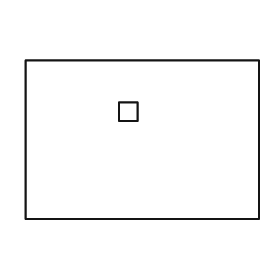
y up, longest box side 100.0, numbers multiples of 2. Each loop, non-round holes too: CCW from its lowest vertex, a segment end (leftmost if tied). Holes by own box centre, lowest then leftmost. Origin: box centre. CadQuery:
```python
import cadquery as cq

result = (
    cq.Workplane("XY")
    .moveTo(-50.0, -34.0)
    .lineTo(50.0, -34.0)
    .lineTo(50.0, 34.0)
    .lineTo(-50.0, 34.0)
    .close()
    .moveTo(-10.0, 8.0)
    .lineTo(-2.0, 8.0)
    .lineTo(-2.0, 16.0)
    .lineTo(-10.0, 16.0)
    .close()
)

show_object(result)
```